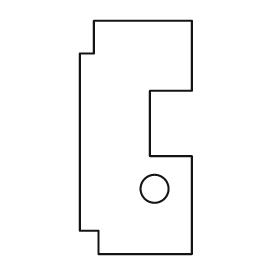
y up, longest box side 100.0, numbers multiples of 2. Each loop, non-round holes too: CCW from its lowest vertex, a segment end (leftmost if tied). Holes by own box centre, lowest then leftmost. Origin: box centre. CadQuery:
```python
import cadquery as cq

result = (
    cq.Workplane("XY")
    .moveTo(-16.0, -50.0)
    .lineTo(24.0, -50.0)
    .lineTo(24.0, -8.0)
    .lineTo(6.0, -8.0)
    .lineTo(6.0, 20.0)
    .lineTo(24.0, 20.0)
    .lineTo(24.0, 50.0)
    .lineTo(-18.0, 50.0)
    .lineTo(-18.0, 36.0)
    .lineTo(-24.0, 36.0)
    .lineTo(-24.0, -40.0)
    .lineTo(-16.0, -40.0)
    .close()
    .moveTo(8.0, -22.0)
    .circle(6.0)
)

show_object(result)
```